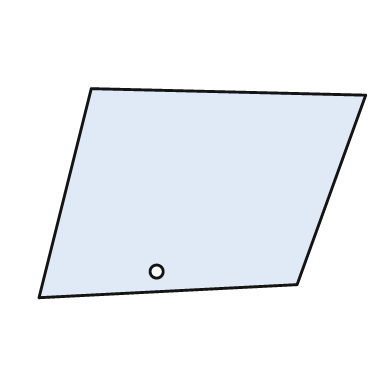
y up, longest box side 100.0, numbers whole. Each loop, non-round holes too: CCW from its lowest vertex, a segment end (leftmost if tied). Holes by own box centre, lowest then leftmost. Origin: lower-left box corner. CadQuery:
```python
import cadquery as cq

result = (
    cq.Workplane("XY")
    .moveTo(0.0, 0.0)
    .lineTo(79.0, 4.0)
    .lineTo(100.0, 62.0)
    .lineTo(16.0, 64.0)
    .close()
    .moveTo(36.0, 8.0)
    .circle(2.0)
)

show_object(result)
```